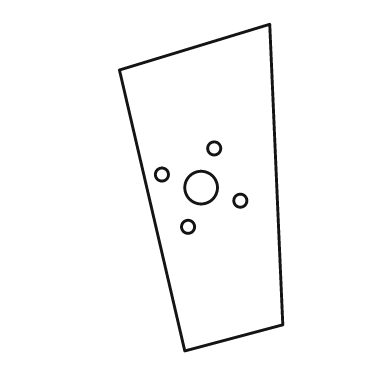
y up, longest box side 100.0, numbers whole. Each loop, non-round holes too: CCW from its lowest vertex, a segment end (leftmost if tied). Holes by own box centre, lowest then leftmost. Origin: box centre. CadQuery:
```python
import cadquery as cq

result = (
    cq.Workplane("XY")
    .moveTo(-5.0, -50.0)
    .lineTo(25.0, -42.0)
    .lineTo(21.0, 50.0)
    .lineTo(-25.0, 36.0)
    .close()
    .moveTo(-4.0, -12.0)
    .circle(2.0)
    .moveTo(12.0, -4.0)
    .circle(2.0)
    .moveTo(0.0, 0.0)
    .circle(5.0)
    .moveTo(-12.0, 4.0)
    .circle(2.0)
    .moveTo(4.0, 12.0)
    .circle(2.0)
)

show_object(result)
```